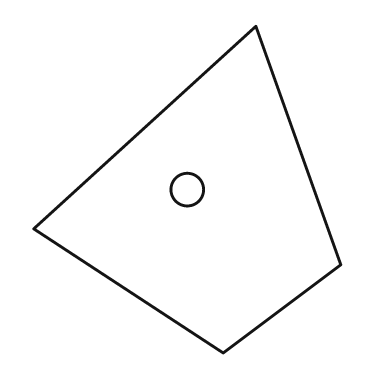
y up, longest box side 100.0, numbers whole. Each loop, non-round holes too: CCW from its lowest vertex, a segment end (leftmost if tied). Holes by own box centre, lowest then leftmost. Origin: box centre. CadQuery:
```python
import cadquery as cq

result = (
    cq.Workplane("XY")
    .moveTo(11.0, -50.0)
    .lineTo(47.0, -23.0)
    .lineTo(21.0, 50.0)
    .lineTo(-47.0, -12.0)
    .close()
    .moveTo(0.0, 0.0)
    .circle(5.0)
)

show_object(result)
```